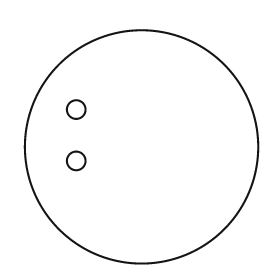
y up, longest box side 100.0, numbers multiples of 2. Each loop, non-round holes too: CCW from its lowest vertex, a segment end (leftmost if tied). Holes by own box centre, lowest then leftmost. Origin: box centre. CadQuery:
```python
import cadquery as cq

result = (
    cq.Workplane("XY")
    .moveTo(0.0, 0.0)
    .circle(50.0)
    .moveTo(-28.0, -6.0)
    .circle(4.0)
    .moveTo(-28.0, 16.0)
    .circle(4.0)
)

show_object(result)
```